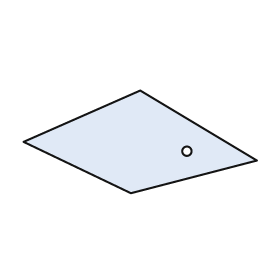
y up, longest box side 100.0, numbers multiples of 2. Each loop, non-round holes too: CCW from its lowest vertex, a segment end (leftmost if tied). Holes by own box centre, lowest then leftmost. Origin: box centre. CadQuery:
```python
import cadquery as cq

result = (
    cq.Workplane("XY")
    .moveTo(-4.0, -22.0)
    .lineTo(50.0, -8.0)
    .lineTo(0.0, 22.0)
    .lineTo(-50.0, 0.0)
    .close()
    .moveTo(20.0, -4.0)
    .circle(2.0)
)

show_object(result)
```